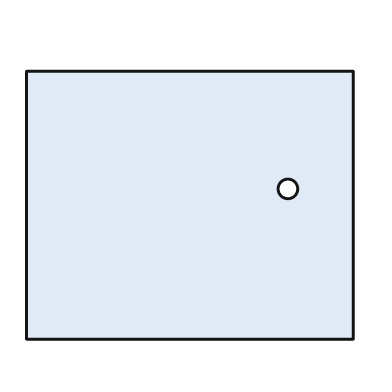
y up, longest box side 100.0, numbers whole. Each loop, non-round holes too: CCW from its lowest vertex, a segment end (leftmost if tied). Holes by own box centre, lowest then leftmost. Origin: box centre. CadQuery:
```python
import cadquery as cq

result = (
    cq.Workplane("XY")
    .moveTo(-50.0, -41.0)
    .lineTo(50.0, -41.0)
    .lineTo(50.0, 41.0)
    .lineTo(-50.0, 41.0)
    .close()
    .moveTo(30.0, 5.0)
    .circle(3.0)
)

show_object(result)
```